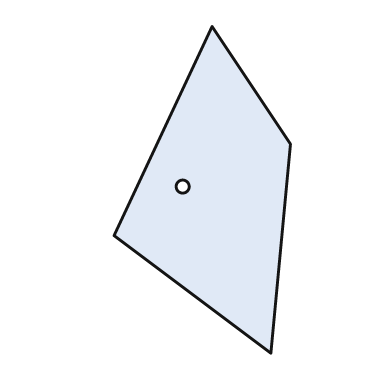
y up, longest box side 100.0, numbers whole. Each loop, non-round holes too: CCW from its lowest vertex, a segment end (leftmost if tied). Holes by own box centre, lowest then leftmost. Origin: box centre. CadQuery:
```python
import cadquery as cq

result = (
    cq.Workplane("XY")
    .moveTo(21.0, -50.0)
    .lineTo(27.0, 14.0)
    .lineTo(3.0, 50.0)
    .lineTo(-27.0, -14.0)
    .close()
    .moveTo(-6.0, 1.0)
    .circle(2.0)
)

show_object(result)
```